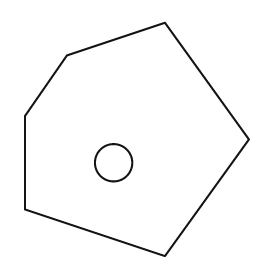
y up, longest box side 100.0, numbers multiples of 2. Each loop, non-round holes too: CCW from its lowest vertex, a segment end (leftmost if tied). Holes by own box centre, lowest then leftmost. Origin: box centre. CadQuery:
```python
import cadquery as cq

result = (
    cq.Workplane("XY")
    .moveTo(12.0, -50.0)
    .lineTo(48.0, 0.0)
    .lineTo(12.0, 50.0)
    .lineTo(-30.0, 36.0)
    .lineTo(-48.0, 10.0)
    .lineTo(-48.0, -30.0)
    .close()
    .moveTo(-10.0, -10.0)
    .circle(8.0)
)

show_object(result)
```